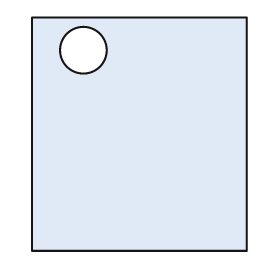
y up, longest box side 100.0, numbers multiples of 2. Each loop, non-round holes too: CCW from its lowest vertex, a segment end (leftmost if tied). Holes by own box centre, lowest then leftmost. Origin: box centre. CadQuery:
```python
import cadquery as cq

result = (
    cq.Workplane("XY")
    .moveTo(-46.0, -50.0)
    .lineTo(46.0, -50.0)
    .lineTo(46.0, 50.0)
    .lineTo(-46.0, 50.0)
    .close()
    .moveTo(-24.0, 36.0)
    .circle(10.0)
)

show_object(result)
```